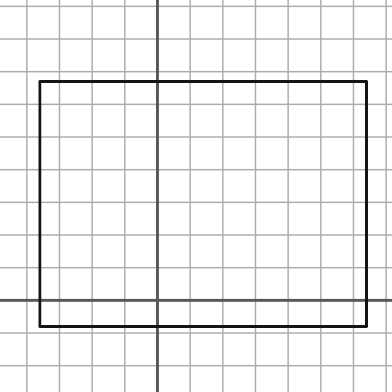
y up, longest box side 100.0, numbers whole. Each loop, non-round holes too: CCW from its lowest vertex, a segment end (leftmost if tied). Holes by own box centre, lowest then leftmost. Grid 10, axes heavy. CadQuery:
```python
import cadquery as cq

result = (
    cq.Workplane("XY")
    .moveTo(-36.0, -8.0)
    .lineTo(64.0, -8.0)
    .lineTo(64.0, 67.0)
    .lineTo(-36.0, 67.0)
    .close()
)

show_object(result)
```